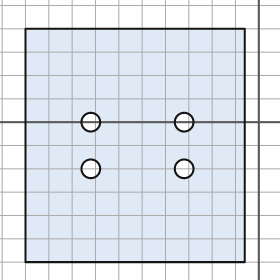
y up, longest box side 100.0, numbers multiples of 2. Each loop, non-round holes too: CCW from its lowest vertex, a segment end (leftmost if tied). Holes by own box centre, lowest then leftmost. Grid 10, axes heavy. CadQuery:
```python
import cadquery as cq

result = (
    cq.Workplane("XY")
    .moveTo(-100.0, -60.0)
    .lineTo(-6.0, -60.0)
    .lineTo(-6.0, 40.0)
    .lineTo(-100.0, 40.0)
    .close()
    .moveTo(-72.0, -20.0)
    .circle(4.0)
    .moveTo(-32.0, -20.0)
    .circle(4.0)
    .moveTo(-72.0, 0.0)
    .circle(4.0)
    .moveTo(-32.0, 0.0)
    .circle(4.0)
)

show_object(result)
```